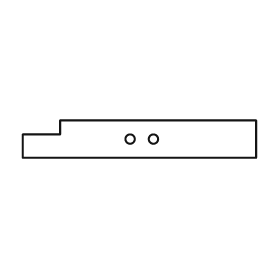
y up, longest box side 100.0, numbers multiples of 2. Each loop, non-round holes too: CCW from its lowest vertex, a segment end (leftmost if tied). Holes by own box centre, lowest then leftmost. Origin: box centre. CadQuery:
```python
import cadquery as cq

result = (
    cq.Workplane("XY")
    .moveTo(-50.0, -8.0)
    .lineTo(50.0, -8.0)
    .lineTo(50.0, 8.0)
    .lineTo(-34.0, 8.0)
    .lineTo(-34.0, 2.0)
    .lineTo(-50.0, 2.0)
    .close()
    .moveTo(-4.0, 0.0)
    .circle(2.0)
    .moveTo(6.0, 0.0)
    .circle(2.0)
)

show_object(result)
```